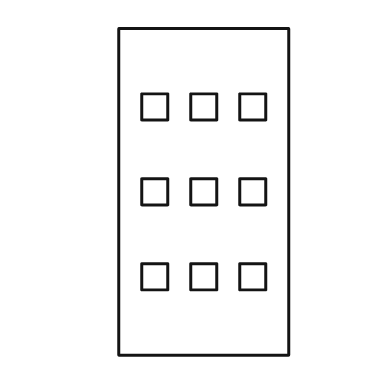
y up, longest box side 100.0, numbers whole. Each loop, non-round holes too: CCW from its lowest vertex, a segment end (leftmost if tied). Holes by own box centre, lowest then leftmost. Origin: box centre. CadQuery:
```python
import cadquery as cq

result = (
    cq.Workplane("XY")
    .moveTo(-26.0, -50.0)
    .lineTo(26.0, -50.0)
    .lineTo(26.0, 50.0)
    .lineTo(-26.0, 50.0)
    .close()
    .moveTo(-19.0, -30.0)
    .lineTo(-11.0, -30.0)
    .lineTo(-11.0, -22.0)
    .lineTo(-19.0, -22.0)
    .close()
    .moveTo(-4.0, -30.0)
    .lineTo(4.0, -30.0)
    .lineTo(4.0, -22.0)
    .lineTo(-4.0, -22.0)
    .close()
    .moveTo(11.0, -30.0)
    .lineTo(19.0, -30.0)
    .lineTo(19.0, -22.0)
    .lineTo(11.0, -22.0)
    .close()
    .moveTo(-19.0, -4.0)
    .lineTo(-11.0, -4.0)
    .lineTo(-11.0, 4.0)
    .lineTo(-19.0, 4.0)
    .close()
    .moveTo(-4.0, -4.0)
    .lineTo(4.0, -4.0)
    .lineTo(4.0, 4.0)
    .lineTo(-4.0, 4.0)
    .close()
    .moveTo(11.0, -4.0)
    .lineTo(19.0, -4.0)
    .lineTo(19.0, 4.0)
    .lineTo(11.0, 4.0)
    .close()
    .moveTo(-19.0, 22.0)
    .lineTo(-11.0, 22.0)
    .lineTo(-11.0, 30.0)
    .lineTo(-19.0, 30.0)
    .close()
    .moveTo(-4.0, 22.0)
    .lineTo(4.0, 22.0)
    .lineTo(4.0, 30.0)
    .lineTo(-4.0, 30.0)
    .close()
    .moveTo(11.0, 22.0)
    .lineTo(19.0, 22.0)
    .lineTo(19.0, 30.0)
    .lineTo(11.0, 30.0)
    .close()
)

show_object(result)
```